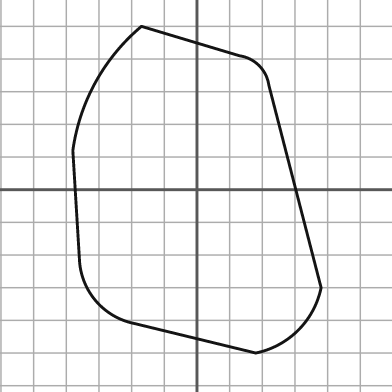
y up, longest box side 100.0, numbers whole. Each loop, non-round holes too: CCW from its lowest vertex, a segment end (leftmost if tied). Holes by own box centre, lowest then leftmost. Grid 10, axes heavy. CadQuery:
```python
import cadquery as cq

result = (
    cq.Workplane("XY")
    .moveTo(18.0, -50.0)
    .threePointArc((31.0, -43.0), (38.0, -30.0))
    .lineTo(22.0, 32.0)
    .threePointArc((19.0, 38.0), (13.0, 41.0))
    .lineTo(-17.0, 50.0)
    .threePointArc((-31.0, 33.0), (-38.0, 12.0))
    .lineTo(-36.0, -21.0)
    .threePointArc((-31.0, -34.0), (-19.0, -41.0))
    .close()
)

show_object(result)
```